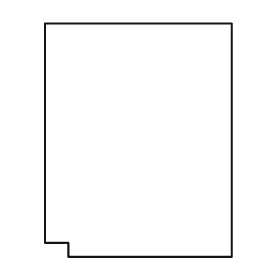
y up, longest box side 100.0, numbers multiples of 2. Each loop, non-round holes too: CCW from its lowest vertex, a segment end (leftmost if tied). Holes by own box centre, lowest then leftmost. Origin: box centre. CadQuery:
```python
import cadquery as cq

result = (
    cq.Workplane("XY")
    .moveTo(-30.0, -50.0)
    .lineTo(40.0, -50.0)
    .lineTo(40.0, 50.0)
    .lineTo(-40.0, 50.0)
    .lineTo(-40.0, -44.0)
    .lineTo(-30.0, -44.0)
    .close()
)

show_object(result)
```